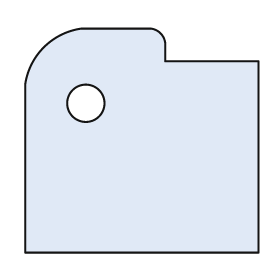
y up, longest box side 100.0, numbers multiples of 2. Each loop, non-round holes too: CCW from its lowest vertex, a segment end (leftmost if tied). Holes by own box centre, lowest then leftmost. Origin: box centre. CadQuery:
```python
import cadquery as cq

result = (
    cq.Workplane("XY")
    .moveTo(-50.0, -48.0)
    .lineTo(50.0, -48.0)
    .lineTo(50.0, 34.0)
    .lineTo(10.0, 34.0)
    .lineTo(10.0, 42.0)
    .threePointArc((8.0, 46.0), (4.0, 48.0))
    .lineTo(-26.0, 48.0)
    .threePointArc((-42.0, 40.0), (-50.0, 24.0))
    .close()
    .moveTo(-24.0, 16.0)
    .circle(8.0)
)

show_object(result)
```